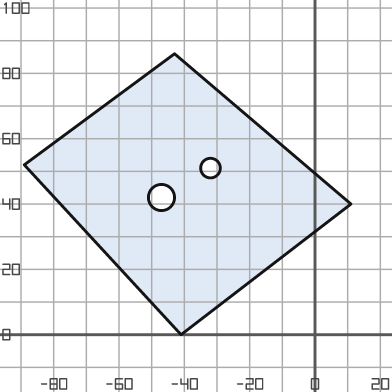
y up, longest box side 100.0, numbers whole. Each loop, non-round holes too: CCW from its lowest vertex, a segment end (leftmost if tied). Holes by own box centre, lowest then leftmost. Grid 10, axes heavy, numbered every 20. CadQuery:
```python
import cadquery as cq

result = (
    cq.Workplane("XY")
    .moveTo(-41.0, 0.0)
    .lineTo(11.0, 40.0)
    .lineTo(-43.0, 86.0)
    .lineTo(-89.0, 52.0)
    .close()
    .moveTo(-47.0, 42.0)
    .circle(4.0)
    .moveTo(-32.0, 51.0)
    .circle(3.0)
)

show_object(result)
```